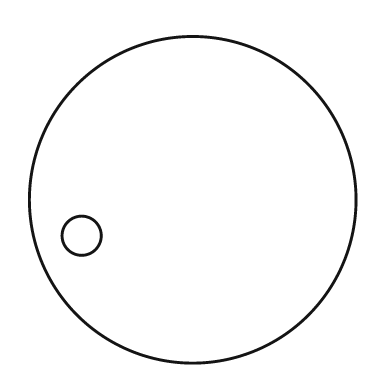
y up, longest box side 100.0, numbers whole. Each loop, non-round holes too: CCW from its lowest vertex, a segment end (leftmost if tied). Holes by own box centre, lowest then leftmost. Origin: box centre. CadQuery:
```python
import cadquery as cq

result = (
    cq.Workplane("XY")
    .moveTo(0.0, 0.0)
    .circle(50.0)
    .moveTo(-34.0, -11.0)
    .circle(6.0)
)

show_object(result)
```